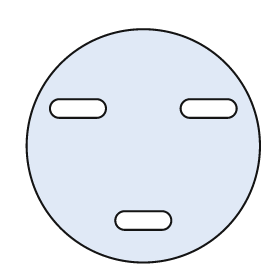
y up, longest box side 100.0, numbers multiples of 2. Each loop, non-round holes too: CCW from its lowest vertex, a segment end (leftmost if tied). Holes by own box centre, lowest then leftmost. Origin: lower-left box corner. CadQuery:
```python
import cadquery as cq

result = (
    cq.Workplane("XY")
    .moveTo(50.0, 50.0)
    .circle(50.0)
    .moveTo(42.0, 14.0)
    .lineTo(58.0, 14.0)
    .threePointArc((62.0, 18.0), (58.0, 22.0))
    .lineTo(42.0, 22.0)
    .threePointArc((38.0, 18.0), (42.0, 14.0))
    .close()
    .moveTo(14.0, 62.0)
    .lineTo(30.0, 62.0)
    .threePointArc((34.0, 66.0), (30.0, 70.0))
    .lineTo(14.0, 70.0)
    .threePointArc((10.0, 66.0), (14.0, 62.0))
    .close()
    .moveTo(70.0, 62.0)
    .lineTo(86.0, 62.0)
    .threePointArc((90.0, 66.0), (86.0, 70.0))
    .lineTo(70.0, 70.0)
    .threePointArc((66.0, 66.0), (70.0, 62.0))
    .close()
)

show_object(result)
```